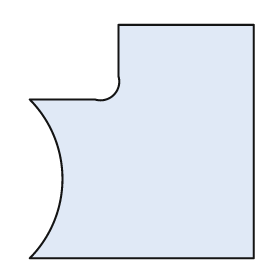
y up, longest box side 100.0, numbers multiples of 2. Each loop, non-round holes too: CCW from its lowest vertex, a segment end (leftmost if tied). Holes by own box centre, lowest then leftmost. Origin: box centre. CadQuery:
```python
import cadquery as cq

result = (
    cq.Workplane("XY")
    .moveTo(-48.0, -50.0)
    .lineTo(48.0, -50.0)
    .lineTo(48.0, 50.0)
    .lineTo(-10.0, 50.0)
    .lineTo(-10.0, 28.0)
    .threePointArc((-12.0, 20.0), (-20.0, 18.0))
    .lineTo(-48.0, 18.0)
    .threePointArc((-34.0, -16.0), (-48.0, -50.0))
    .close()
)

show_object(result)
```